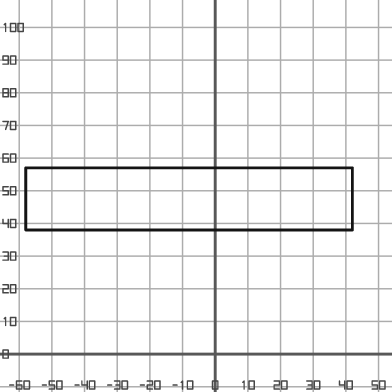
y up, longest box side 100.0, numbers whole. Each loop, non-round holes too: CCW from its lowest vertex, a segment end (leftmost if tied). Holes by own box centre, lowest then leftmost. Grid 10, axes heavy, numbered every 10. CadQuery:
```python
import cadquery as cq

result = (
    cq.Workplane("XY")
    .moveTo(-58.0, 38.0)
    .lineTo(42.0, 38.0)
    .lineTo(42.0, 57.0)
    .lineTo(-58.0, 57.0)
    .close()
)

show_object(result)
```